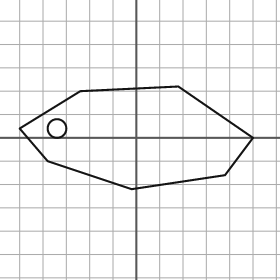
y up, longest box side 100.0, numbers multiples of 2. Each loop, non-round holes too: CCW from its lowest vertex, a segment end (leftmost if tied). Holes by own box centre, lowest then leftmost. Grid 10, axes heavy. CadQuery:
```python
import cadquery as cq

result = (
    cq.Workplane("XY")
    .moveTo(-2.0, -22.0)
    .lineTo(38.0, -16.0)
    .lineTo(50.0, 0.0)
    .lineTo(18.0, 22.0)
    .lineTo(-24.0, 20.0)
    .lineTo(-50.0, 4.0)
    .lineTo(-38.0, -10.0)
    .close()
    .moveTo(-34.0, 4.0)
    .circle(4.0)
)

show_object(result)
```